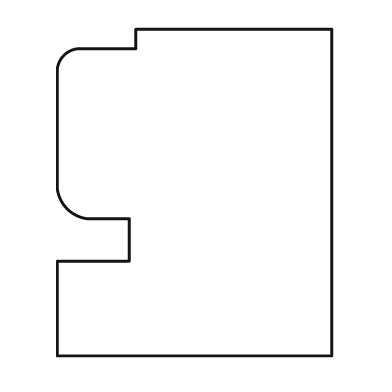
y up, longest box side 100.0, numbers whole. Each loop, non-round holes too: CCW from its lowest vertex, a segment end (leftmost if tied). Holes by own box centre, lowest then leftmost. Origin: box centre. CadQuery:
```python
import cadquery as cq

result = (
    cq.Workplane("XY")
    .moveTo(-42.0, -50.0)
    .lineTo(42.0, -50.0)
    .lineTo(42.0, 50.0)
    .lineTo(-18.0, 50.0)
    .lineTo(-18.0, 44.0)
    .lineTo(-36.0, 44.0)
    .threePointArc((-40.0, 42.0), (-42.0, 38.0))
    .lineTo(-42.0, 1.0)
    .threePointArc((-39.0, -5.0), (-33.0, -8.0))
    .lineTo(-20.0, -8.0)
    .lineTo(-20.0, -21.0)
    .lineTo(-42.0, -21.0)
    .close()
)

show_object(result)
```